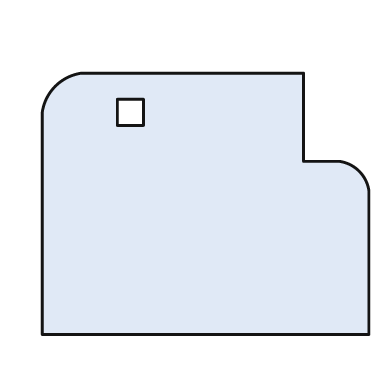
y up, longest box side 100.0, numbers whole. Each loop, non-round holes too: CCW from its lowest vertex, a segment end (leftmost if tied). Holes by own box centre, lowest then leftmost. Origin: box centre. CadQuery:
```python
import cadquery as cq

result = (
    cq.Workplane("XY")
    .moveTo(-50.0, -40.0)
    .lineTo(50.0, -40.0)
    .lineTo(50.0, 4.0)
    .threePointArc((47.0, 10.0), (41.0, 13.0))
    .lineTo(30.0, 13.0)
    .lineTo(30.0, 40.0)
    .lineTo(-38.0, 40.0)
    .threePointArc((-46.0, 36.0), (-50.0, 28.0))
    .close()
    .moveTo(-27.0, 24.0)
    .lineTo(-19.0, 24.0)
    .lineTo(-19.0, 32.0)
    .lineTo(-27.0, 32.0)
    .close()
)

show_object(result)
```